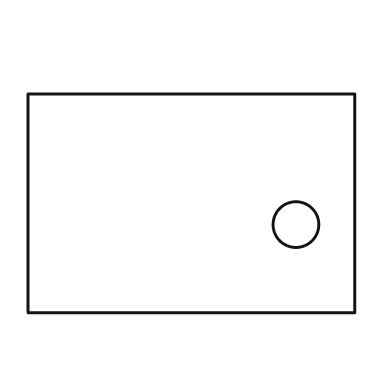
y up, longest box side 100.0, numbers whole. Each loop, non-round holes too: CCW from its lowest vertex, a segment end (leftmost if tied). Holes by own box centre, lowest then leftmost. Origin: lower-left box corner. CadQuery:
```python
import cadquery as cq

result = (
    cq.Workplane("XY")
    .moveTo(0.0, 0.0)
    .lineTo(100.0, 0.0)
    .lineTo(100.0, 67.0)
    .lineTo(0.0, 67.0)
    .close()
    .moveTo(82.0, 27.0)
    .circle(7.0)
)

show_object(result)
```